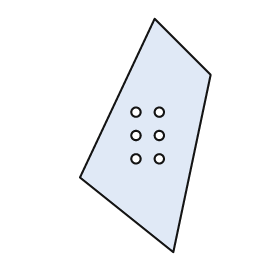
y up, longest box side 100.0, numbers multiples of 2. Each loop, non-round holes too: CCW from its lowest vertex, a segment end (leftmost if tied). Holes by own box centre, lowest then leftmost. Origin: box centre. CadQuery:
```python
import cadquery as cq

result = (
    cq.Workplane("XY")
    .moveTo(12.0, -50.0)
    .lineTo(28.0, 26.0)
    .lineTo(4.0, 50.0)
    .lineTo(-28.0, -18.0)
    .close()
    .moveTo(-4.0, -10.0)
    .circle(2.0)
    .moveTo(6.0, -10.0)
    .circle(2.0)
    .moveTo(-4.0, 0.0)
    .circle(2.0)
    .moveTo(6.0, 0.0)
    .circle(2.0)
    .moveTo(-4.0, 10.0)
    .circle(2.0)
    .moveTo(6.0, 10.0)
    .circle(2.0)
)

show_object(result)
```